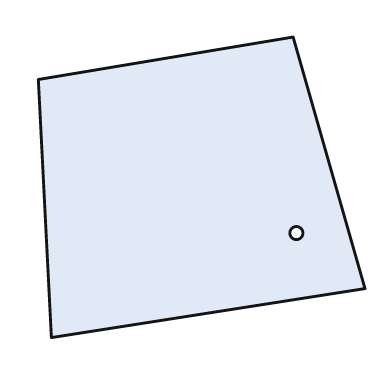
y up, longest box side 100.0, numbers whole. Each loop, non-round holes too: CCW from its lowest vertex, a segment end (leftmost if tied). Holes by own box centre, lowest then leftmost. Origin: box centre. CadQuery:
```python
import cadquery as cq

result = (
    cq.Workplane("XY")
    .moveTo(-46.0, -46.0)
    .lineTo(50.0, -31.0)
    .lineTo(28.0, 46.0)
    .lineTo(-50.0, 33.0)
    .close()
    .moveTo(29.0, -14.0)
    .circle(2.0)
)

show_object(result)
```